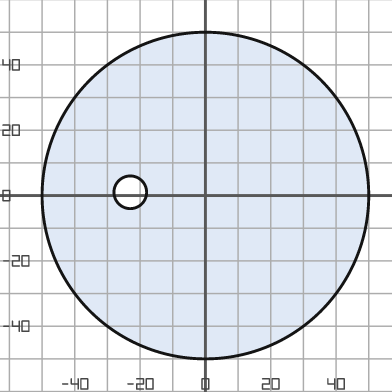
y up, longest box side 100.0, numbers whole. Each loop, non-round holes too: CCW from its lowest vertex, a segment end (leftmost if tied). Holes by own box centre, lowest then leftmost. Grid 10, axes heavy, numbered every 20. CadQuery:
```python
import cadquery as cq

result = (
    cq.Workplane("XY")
    .moveTo(0.0, 0.0)
    .circle(50.0)
    .moveTo(-23.0, 1.0)
    .circle(5.0)
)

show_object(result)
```